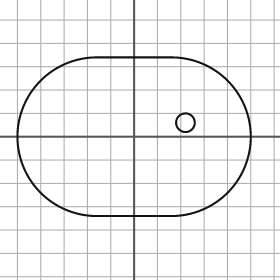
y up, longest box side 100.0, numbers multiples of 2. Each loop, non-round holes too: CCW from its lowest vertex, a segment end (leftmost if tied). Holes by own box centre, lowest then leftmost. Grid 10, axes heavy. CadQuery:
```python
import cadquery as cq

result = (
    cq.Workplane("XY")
    .moveTo(-16.0, -34.0)
    .lineTo(16.0, -34.0)
    .threePointArc((50.0, 0.0), (16.0, 34.0))
    .lineTo(-16.0, 34.0)
    .threePointArc((-50.0, 0.0), (-16.0, -34.0))
    .close()
    .moveTo(22.0, 6.0)
    .circle(4.0)
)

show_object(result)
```